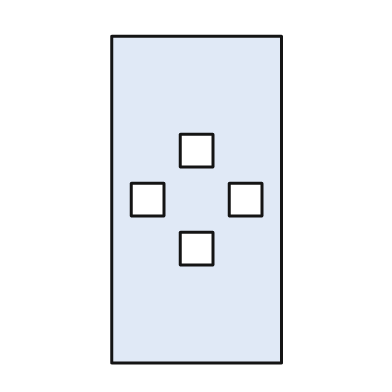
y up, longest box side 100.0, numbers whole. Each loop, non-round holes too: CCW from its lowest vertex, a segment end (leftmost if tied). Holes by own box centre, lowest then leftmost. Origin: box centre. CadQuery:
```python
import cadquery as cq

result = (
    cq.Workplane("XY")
    .moveTo(-26.0, -50.0)
    .lineTo(26.0, -50.0)
    .lineTo(26.0, 50.0)
    .lineTo(-26.0, 50.0)
    .close()
    .moveTo(-5.0, -20.0)
    .lineTo(5.0, -20.0)
    .lineTo(5.0, -10.0)
    .lineTo(-5.0, -10.0)
    .close()
    .moveTo(-20.0, -5.0)
    .lineTo(-10.0, -5.0)
    .lineTo(-10.0, 5.0)
    .lineTo(-20.0, 5.0)
    .close()
    .moveTo(10.0, -5.0)
    .lineTo(20.0, -5.0)
    .lineTo(20.0, 5.0)
    .lineTo(10.0, 5.0)
    .close()
    .moveTo(-5.0, 10.0)
    .lineTo(5.0, 10.0)
    .lineTo(5.0, 20.0)
    .lineTo(-5.0, 20.0)
    .close()
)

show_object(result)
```